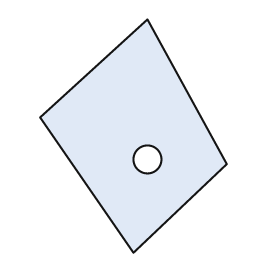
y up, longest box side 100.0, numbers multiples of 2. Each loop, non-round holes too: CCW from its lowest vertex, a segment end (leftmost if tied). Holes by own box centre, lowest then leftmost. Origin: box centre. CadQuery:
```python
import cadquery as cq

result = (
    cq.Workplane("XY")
    .moveTo(0.0, -50.0)
    .lineTo(40.0, -12.0)
    .lineTo(6.0, 50.0)
    .lineTo(-40.0, 8.0)
    .close()
    .moveTo(6.0, -10.0)
    .circle(6.0)
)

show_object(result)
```